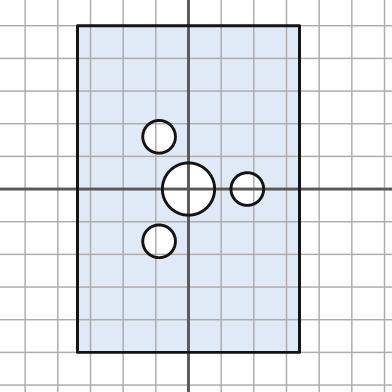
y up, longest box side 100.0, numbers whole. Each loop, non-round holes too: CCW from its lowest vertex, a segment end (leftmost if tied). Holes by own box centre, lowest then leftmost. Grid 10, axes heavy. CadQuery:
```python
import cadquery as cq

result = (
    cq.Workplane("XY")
    .moveTo(-34.0, -50.0)
    .lineTo(34.0, -50.0)
    .lineTo(34.0, 50.0)
    .lineTo(-34.0, 50.0)
    .close()
    .moveTo(-9.0, -16.0)
    .circle(5.0)
    .moveTo(0.0, 0.0)
    .circle(8.0)
    .moveTo(18.0, 0.0)
    .circle(5.0)
    .moveTo(-9.0, 16.0)
    .circle(5.0)
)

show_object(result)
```